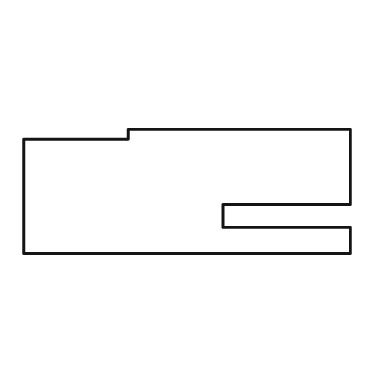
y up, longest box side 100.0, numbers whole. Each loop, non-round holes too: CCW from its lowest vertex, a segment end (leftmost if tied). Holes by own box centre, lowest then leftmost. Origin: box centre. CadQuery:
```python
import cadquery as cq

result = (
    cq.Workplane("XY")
    .moveTo(-50.0, -19.0)
    .lineTo(50.0, -19.0)
    .lineTo(50.0, -11.0)
    .lineTo(11.0, -11.0)
    .lineTo(11.0, -4.0)
    .lineTo(50.0, -4.0)
    .lineTo(50.0, 19.0)
    .lineTo(-18.0, 19.0)
    .lineTo(-18.0, 16.0)
    .lineTo(-50.0, 16.0)
    .close()
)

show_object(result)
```